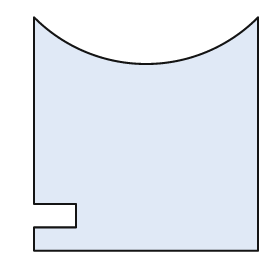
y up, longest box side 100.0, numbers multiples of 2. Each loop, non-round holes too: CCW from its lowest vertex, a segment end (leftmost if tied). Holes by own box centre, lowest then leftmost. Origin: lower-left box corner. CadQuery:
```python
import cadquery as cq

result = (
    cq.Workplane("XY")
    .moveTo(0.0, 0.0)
    .lineTo(96.0, 0.0)
    .lineTo(96.0, 100.0)
    .threePointArc((48.0, 80.0), (0.0, 100.0))
    .lineTo(0.0, 20.0)
    .lineTo(18.0, 20.0)
    .lineTo(18.0, 10.0)
    .lineTo(0.0, 10.0)
    .close()
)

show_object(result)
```